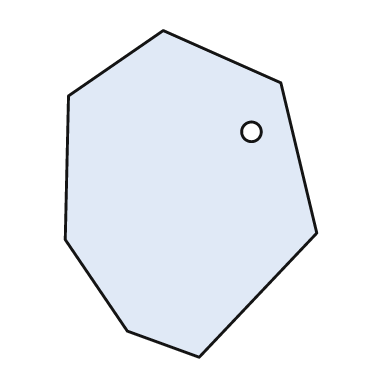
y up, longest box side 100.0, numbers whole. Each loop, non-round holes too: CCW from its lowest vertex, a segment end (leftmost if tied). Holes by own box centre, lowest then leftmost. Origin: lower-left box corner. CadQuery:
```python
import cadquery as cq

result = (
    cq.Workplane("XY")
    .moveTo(41.0, 0.0)
    .lineTo(77.0, 38.0)
    .lineTo(66.0, 84.0)
    .lineTo(30.0, 100.0)
    .lineTo(1.0, 80.0)
    .lineTo(0.0, 36.0)
    .lineTo(19.0, 8.0)
    .close()
    .moveTo(57.0, 69.0)
    .circle(3.0)
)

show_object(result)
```